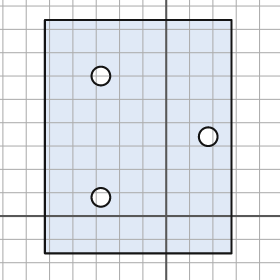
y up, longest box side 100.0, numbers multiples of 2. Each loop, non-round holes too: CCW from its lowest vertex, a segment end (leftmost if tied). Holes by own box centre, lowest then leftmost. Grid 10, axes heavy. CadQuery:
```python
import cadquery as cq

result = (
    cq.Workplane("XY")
    .moveTo(-52.0, -16.0)
    .lineTo(28.0, -16.0)
    .lineTo(28.0, 84.0)
    .lineTo(-52.0, 84.0)
    .close()
    .moveTo(-28.0, 8.0)
    .circle(4.0)
    .moveTo(18.0, 34.0)
    .circle(4.0)
    .moveTo(-28.0, 60.0)
    .circle(4.0)
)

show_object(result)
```